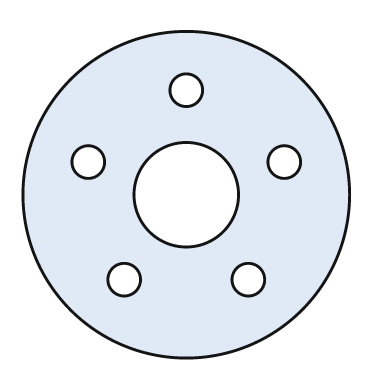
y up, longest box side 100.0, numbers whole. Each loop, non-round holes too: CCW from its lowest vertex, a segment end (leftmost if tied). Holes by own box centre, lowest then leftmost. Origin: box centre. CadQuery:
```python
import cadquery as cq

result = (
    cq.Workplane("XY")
    .moveTo(0.0, 0.0)
    .circle(50.0)
    .moveTo(-19.0, -26.0)
    .circle(5.0)
    .moveTo(19.0, -26.0)
    .circle(5.0)
    .moveTo(0.0, 0.0)
    .circle(16.0)
    .moveTo(-30.0, 10.0)
    .circle(5.0)
    .moveTo(30.0, 10.0)
    .circle(5.0)
    .moveTo(0.0, 32.0)
    .circle(5.0)
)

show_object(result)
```